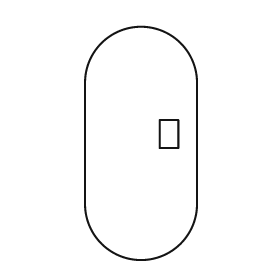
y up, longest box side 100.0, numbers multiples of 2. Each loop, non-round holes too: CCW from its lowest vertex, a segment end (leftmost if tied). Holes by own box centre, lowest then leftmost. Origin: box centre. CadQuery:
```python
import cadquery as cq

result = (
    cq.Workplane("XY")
    .moveTo(-24.0, -26.0)
    .threePointArc((0.0, -50.0), (24.0, -26.0))
    .lineTo(24.0, 26.0)
    .threePointArc((0.0, 50.0), (-24.0, 26.0))
    .close()
    .moveTo(8.0, -2.0)
    .lineTo(16.0, -2.0)
    .lineTo(16.0, 10.0)
    .lineTo(8.0, 10.0)
    .close()
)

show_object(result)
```